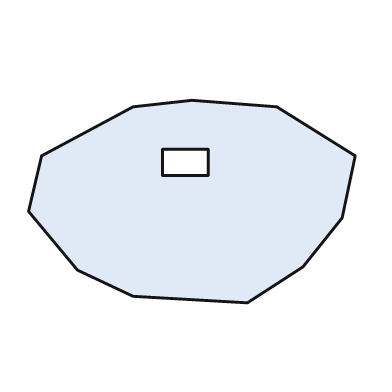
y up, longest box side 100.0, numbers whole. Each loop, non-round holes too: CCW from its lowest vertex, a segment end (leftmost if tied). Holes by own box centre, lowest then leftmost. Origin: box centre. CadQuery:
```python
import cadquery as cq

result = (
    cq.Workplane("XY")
    .moveTo(17.0, -31.0)
    .lineTo(34.0, -20.0)
    .lineTo(46.0, -5.0)
    .lineTo(50.0, 14.0)
    .lineTo(26.0, 29.0)
    .lineTo(0.0, 31.0)
    .lineTo(-18.0, 29.0)
    .lineTo(-46.0, 14.0)
    .lineTo(-50.0, -3.0)
    .lineTo(-35.0, -21.0)
    .lineTo(-18.0, -29.0)
    .close()
    .moveTo(-9.0, 8.0)
    .lineTo(5.0, 8.0)
    .lineTo(5.0, 16.0)
    .lineTo(-9.0, 16.0)
    .close()
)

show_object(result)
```